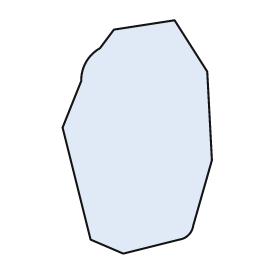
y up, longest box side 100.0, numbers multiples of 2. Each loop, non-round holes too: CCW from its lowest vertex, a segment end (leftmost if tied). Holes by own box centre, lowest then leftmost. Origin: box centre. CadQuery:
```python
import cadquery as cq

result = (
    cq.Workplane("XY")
    .moveTo(-6.0, -50.0)
    .lineTo(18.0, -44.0)
    .threePointArc((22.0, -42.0), (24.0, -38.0))
    .lineTo(32.0, -10.0)
    .lineTo(30.0, 28.0)
    .lineTo(16.0, 50.0)
    .lineTo(-10.0, 46.0)
    .lineTo(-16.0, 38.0)
    .threePointArc((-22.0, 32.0), (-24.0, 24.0))
    .lineTo(-32.0, 4.0)
    .lineTo(-20.0, -44.0)
    .close()
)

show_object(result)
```